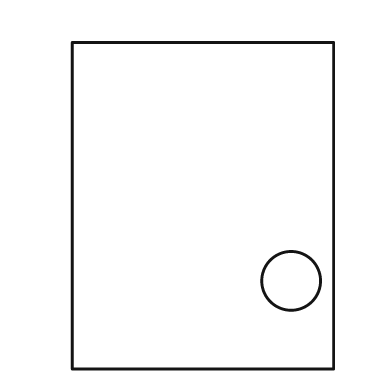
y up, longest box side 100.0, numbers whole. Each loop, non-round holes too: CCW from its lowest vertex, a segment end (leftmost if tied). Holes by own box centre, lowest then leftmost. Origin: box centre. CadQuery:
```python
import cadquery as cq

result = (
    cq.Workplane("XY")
    .moveTo(-40.0, -50.0)
    .lineTo(40.0, -50.0)
    .lineTo(40.0, 50.0)
    .lineTo(-40.0, 50.0)
    .close()
    .moveTo(27.0, -23.0)
    .circle(9.0)
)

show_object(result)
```